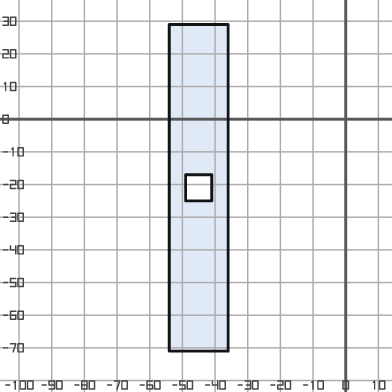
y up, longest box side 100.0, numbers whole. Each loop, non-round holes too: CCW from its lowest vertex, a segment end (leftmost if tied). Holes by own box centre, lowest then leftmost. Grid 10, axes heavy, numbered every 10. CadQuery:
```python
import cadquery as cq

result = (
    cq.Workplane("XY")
    .moveTo(-54.0, -71.0)
    .lineTo(-36.0, -71.0)
    .lineTo(-36.0, 29.0)
    .lineTo(-54.0, 29.0)
    .close()
    .moveTo(-49.0, -25.0)
    .lineTo(-41.0, -25.0)
    .lineTo(-41.0, -17.0)
    .lineTo(-49.0, -17.0)
    .close()
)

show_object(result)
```